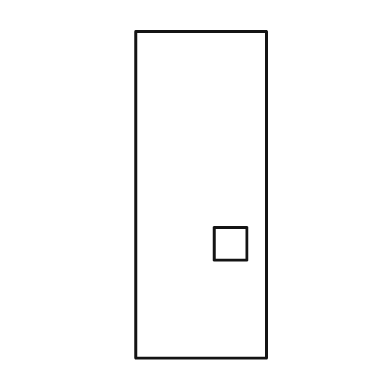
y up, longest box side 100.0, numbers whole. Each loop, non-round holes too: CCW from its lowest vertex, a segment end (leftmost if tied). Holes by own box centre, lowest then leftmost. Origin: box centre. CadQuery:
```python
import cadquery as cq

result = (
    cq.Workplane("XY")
    .moveTo(-20.0, -50.0)
    .lineTo(20.0, -50.0)
    .lineTo(20.0, 50.0)
    .lineTo(-20.0, 50.0)
    .close()
    .moveTo(4.0, -20.0)
    .lineTo(14.0, -20.0)
    .lineTo(14.0, -10.0)
    .lineTo(4.0, -10.0)
    .close()
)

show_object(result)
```